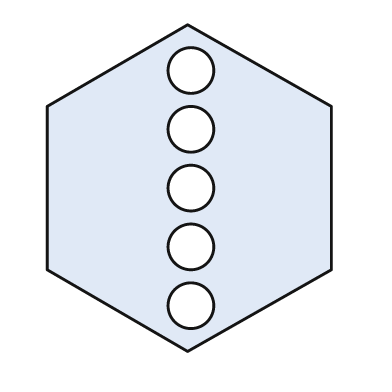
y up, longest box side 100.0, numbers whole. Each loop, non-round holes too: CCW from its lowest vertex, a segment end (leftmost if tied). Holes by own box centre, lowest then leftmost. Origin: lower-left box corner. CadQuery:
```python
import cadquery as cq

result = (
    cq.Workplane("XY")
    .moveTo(43.0, 0.0)
    .lineTo(87.0, 25.0)
    .lineTo(87.0, 75.0)
    .lineTo(43.0, 100.0)
    .lineTo(0.0, 75.0)
    .lineTo(0.0, 25.0)
    .close()
    .moveTo(44.0, 14.0)
    .circle(7.0)
    .moveTo(44.0, 32.0)
    .circle(7.0)
    .moveTo(44.0, 50.0)
    .circle(7.0)
    .moveTo(44.0, 68.0)
    .circle(7.0)
    .moveTo(44.0, 86.0)
    .circle(7.0)
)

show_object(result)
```